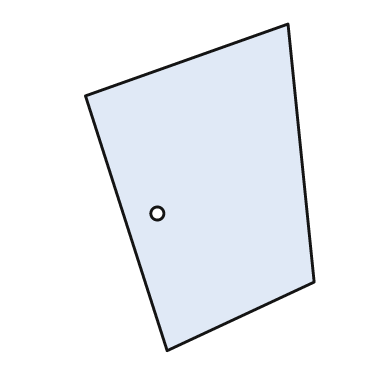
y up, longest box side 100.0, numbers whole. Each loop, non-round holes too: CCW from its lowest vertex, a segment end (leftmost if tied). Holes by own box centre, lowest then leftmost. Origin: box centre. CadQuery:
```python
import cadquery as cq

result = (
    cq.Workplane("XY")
    .moveTo(-10.0, -50.0)
    .lineTo(35.0, -29.0)
    .lineTo(27.0, 50.0)
    .lineTo(-35.0, 28.0)
    .close()
    .moveTo(-13.0, -8.0)
    .circle(2.0)
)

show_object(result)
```